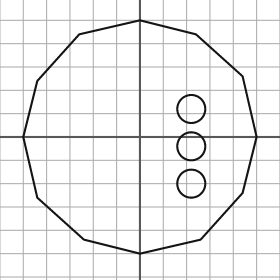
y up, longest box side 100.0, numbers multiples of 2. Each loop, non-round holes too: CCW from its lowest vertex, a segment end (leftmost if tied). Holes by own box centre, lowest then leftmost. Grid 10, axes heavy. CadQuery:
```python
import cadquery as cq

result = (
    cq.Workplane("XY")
    .moveTo(0.0, -50.0)
    .lineTo(26.0, -44.0)
    .lineTo(44.0, -24.0)
    .lineTo(50.0, 0.0)
    .lineTo(44.0, 26.0)
    .lineTo(24.0, 44.0)
    .lineTo(0.0, 50.0)
    .lineTo(-26.0, 44.0)
    .lineTo(-44.0, 24.0)
    .lineTo(-50.0, 0.0)
    .lineTo(-44.0, -26.0)
    .lineTo(-24.0, -44.0)
    .close()
    .moveTo(22.0, -20.0)
    .circle(6.0)
    .moveTo(22.0, -4.0)
    .circle(6.0)
    .moveTo(22.0, 12.0)
    .circle(6.0)
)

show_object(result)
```